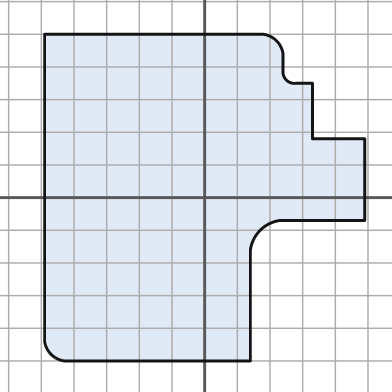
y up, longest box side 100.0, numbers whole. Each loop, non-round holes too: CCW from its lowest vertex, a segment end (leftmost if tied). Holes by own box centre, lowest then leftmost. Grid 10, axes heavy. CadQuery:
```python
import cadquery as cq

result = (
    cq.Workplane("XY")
    .moveTo(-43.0, -50.0)
    .lineTo(14.0, -50.0)
    .lineTo(14.0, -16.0)
    .threePointArc((17.0, -10.0), (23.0, -7.0))
    .lineTo(49.0, -7.0)
    .lineTo(49.0, 18.0)
    .lineTo(33.0, 18.0)
    .lineTo(33.0, 35.0)
    .lineTo(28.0, 35.0)
    .threePointArc((25.0, 36.0), (24.0, 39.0))
    .lineTo(24.0, 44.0)
    .threePointArc((22.0, 48.0), (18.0, 50.0))
    .lineTo(-49.0, 50.0)
    .lineTo(-49.0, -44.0)
    .threePointArc((-47.0, -48.0), (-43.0, -50.0))
    .close()
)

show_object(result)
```